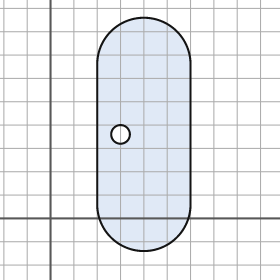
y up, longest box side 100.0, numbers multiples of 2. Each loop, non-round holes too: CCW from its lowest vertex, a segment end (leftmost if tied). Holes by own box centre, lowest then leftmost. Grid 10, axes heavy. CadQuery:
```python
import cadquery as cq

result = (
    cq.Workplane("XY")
    .moveTo(20.0, 6.0)
    .threePointArc((40.0, -14.0), (60.0, 6.0))
    .lineTo(60.0, 66.0)
    .threePointArc((40.0, 86.0), (20.0, 66.0))
    .close()
    .moveTo(30.0, 36.0)
    .circle(4.0)
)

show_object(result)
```